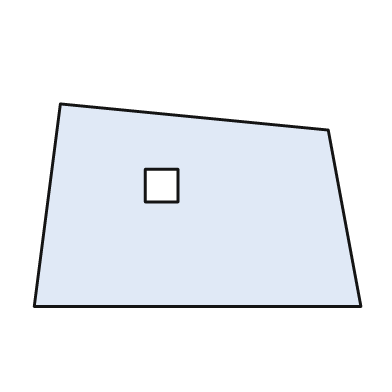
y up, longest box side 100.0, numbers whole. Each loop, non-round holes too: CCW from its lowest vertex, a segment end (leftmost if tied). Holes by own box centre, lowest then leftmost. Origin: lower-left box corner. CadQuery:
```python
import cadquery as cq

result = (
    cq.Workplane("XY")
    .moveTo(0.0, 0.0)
    .lineTo(100.0, 0.0)
    .lineTo(90.0, 54.0)
    .lineTo(8.0, 62.0)
    .close()
    .moveTo(34.0, 32.0)
    .lineTo(44.0, 32.0)
    .lineTo(44.0, 42.0)
    .lineTo(34.0, 42.0)
    .close()
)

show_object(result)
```